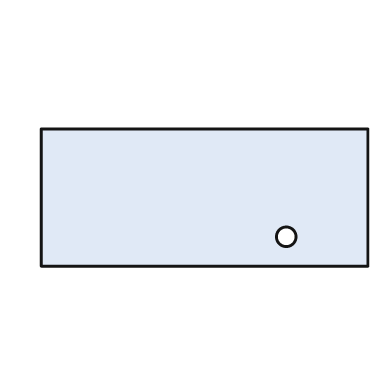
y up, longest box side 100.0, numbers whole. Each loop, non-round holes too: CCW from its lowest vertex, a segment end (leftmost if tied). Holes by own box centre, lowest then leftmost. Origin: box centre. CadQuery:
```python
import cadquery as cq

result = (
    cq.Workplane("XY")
    .moveTo(-50.0, -21.0)
    .lineTo(50.0, -21.0)
    .lineTo(50.0, 21.0)
    .lineTo(-50.0, 21.0)
    .close()
    .moveTo(25.0, -12.0)
    .circle(3.0)
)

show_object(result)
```